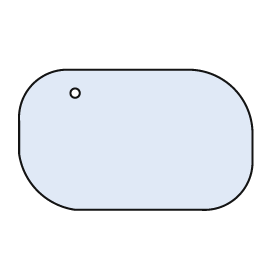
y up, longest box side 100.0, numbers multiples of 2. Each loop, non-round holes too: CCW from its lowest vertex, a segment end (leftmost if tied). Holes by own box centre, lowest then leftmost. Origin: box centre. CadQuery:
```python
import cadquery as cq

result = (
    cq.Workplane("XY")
    .moveTo(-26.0, -30.0)
    .lineTo(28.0, -30.0)
    .threePointArc((44.0, -24.0), (50.0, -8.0))
    .lineTo(50.0, 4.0)
    .threePointArc((42.0, 22.0), (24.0, 30.0))
    .lineTo(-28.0, 30.0)
    .threePointArc((-44.0, 24.0), (-50.0, 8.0))
    .lineTo(-50.0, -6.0)
    .threePointArc((-42.0, -22.0), (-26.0, -30.0))
    .close()
    .moveTo(-26.0, 20.0)
    .circle(2.0)
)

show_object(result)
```